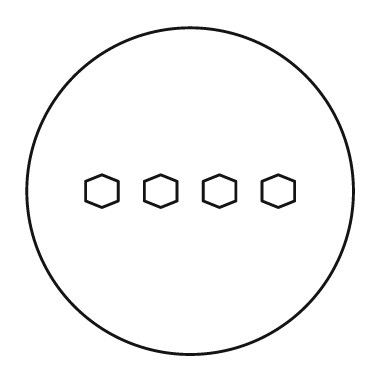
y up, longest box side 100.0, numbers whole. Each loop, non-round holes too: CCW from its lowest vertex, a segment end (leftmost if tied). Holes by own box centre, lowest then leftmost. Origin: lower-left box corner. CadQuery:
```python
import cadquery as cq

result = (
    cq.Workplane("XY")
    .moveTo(50.0, 50.0)
    .circle(50.0)
    .moveTo(23.0, 45.0)
    .lineTo(28.0, 47.0)
    .lineTo(28.0, 53.0)
    .lineTo(23.0, 55.0)
    .lineTo(18.0, 53.0)
    .lineTo(18.0, 47.0)
    .close()
    .moveTo(41.0, 45.0)
    .lineTo(46.0, 47.0)
    .lineTo(46.0, 53.0)
    .lineTo(41.0, 55.0)
    .lineTo(36.0, 53.0)
    .lineTo(36.0, 47.0)
    .close()
    .moveTo(59.0, 45.0)
    .lineTo(64.0, 47.0)
    .lineTo(64.0, 53.0)
    .lineTo(59.0, 55.0)
    .lineTo(54.0, 53.0)
    .lineTo(54.0, 47.0)
    .close()
    .moveTo(77.0, 45.0)
    .lineTo(82.0, 47.0)
    .lineTo(82.0, 53.0)
    .lineTo(77.0, 55.0)
    .lineTo(72.0, 53.0)
    .lineTo(72.0, 47.0)
    .close()
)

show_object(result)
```